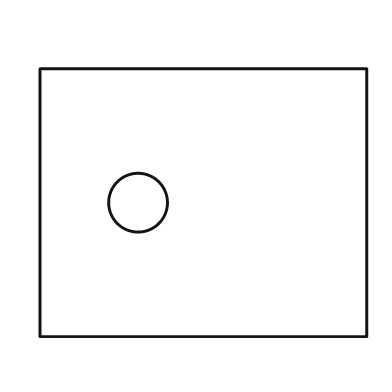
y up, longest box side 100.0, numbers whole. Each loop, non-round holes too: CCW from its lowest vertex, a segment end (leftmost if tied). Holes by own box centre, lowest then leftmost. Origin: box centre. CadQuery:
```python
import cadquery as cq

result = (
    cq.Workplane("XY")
    .moveTo(-50.0, -41.0)
    .lineTo(50.0, -41.0)
    .lineTo(50.0, 41.0)
    .lineTo(-50.0, 41.0)
    .close()
    .moveTo(-20.0, 0.0)
    .circle(9.0)
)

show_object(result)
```